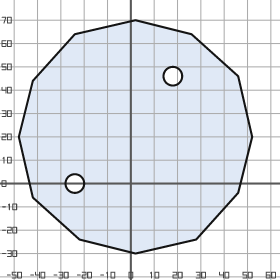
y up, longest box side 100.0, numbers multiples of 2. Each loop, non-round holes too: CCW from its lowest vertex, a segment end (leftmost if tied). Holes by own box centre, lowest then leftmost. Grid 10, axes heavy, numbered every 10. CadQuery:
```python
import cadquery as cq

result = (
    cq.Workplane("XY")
    .moveTo(2.0, -30.0)
    .lineTo(28.0, -24.0)
    .lineTo(46.0, -4.0)
    .lineTo(52.0, 20.0)
    .lineTo(46.0, 46.0)
    .lineTo(26.0, 64.0)
    .lineTo(2.0, 70.0)
    .lineTo(-24.0, 64.0)
    .lineTo(-42.0, 44.0)
    .lineTo(-48.0, 20.0)
    .lineTo(-42.0, -6.0)
    .lineTo(-22.0, -24.0)
    .close()
    .moveTo(-24.0, 0.0)
    .circle(4.0)
    .moveTo(18.0, 46.0)
    .circle(4.0)
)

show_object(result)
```